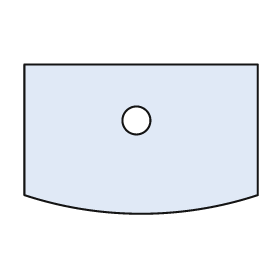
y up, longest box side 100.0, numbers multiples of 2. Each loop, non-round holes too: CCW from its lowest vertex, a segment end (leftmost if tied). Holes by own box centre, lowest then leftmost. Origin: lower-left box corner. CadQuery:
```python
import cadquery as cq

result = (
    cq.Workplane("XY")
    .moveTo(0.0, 8.0)
    .threePointArc((50.0, 0.0), (100.0, 8.0))
    .lineTo(100.0, 64.0)
    .lineTo(0.0, 64.0)
    .close()
    .moveTo(48.0, 40.0)
    .circle(6.0)
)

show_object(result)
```